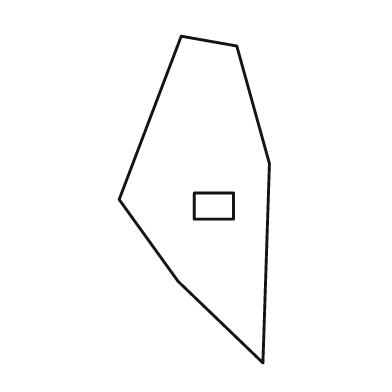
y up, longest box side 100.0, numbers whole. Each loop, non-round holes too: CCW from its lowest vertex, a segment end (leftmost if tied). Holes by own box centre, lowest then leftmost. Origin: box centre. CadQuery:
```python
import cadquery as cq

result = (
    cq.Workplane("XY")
    .moveTo(21.0, -50.0)
    .lineTo(23.0, 11.0)
    .lineTo(13.0, 47.0)
    .lineTo(-4.0, 50.0)
    .lineTo(-23.0, 0.0)
    .lineTo(-5.0, -25.0)
    .close()
    .moveTo(0.0, -6.0)
    .lineTo(12.0, -6.0)
    .lineTo(12.0, 2.0)
    .lineTo(0.0, 2.0)
    .close()
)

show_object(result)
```